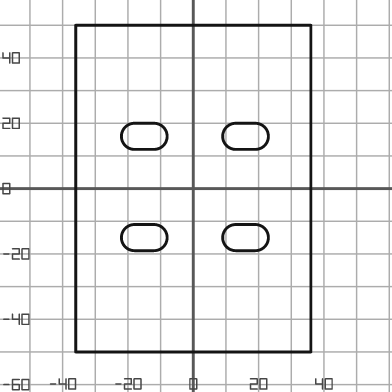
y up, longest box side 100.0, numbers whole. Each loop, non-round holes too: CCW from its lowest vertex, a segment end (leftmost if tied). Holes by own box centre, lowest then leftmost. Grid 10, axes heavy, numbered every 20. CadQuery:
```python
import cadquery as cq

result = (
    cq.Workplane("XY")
    .moveTo(-36.0, -50.0)
    .lineTo(36.0, -50.0)
    .lineTo(36.0, 50.0)
    .lineTo(-36.0, 50.0)
    .close()
    .moveTo(-18.0, -19.0)
    .lineTo(-12.0, -19.0)
    .threePointArc((-8.0, -15.0), (-12.0, -11.0))
    .lineTo(-18.0, -11.0)
    .threePointArc((-22.0, -15.0), (-18.0, -19.0))
    .close()
    .moveTo(13.0, -19.0)
    .lineTo(19.0, -19.0)
    .threePointArc((23.0, -15.0), (19.0, -11.0))
    .lineTo(13.0, -11.0)
    .threePointArc((9.0, -15.0), (13.0, -19.0))
    .close()
    .moveTo(-18.0, 12.0)
    .lineTo(-12.0, 12.0)
    .threePointArc((-8.0, 16.0), (-12.0, 20.0))
    .lineTo(-18.0, 20.0)
    .threePointArc((-22.0, 16.0), (-18.0, 12.0))
    .close()
    .moveTo(13.0, 12.0)
    .lineTo(19.0, 12.0)
    .threePointArc((23.0, 16.0), (19.0, 20.0))
    .lineTo(13.0, 20.0)
    .threePointArc((9.0, 16.0), (13.0, 12.0))
    .close()
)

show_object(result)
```